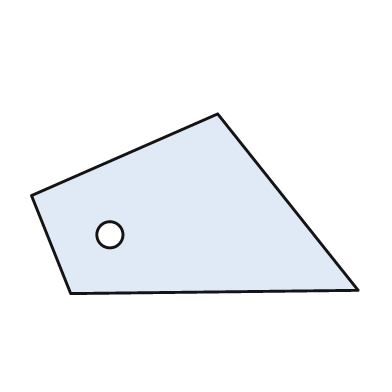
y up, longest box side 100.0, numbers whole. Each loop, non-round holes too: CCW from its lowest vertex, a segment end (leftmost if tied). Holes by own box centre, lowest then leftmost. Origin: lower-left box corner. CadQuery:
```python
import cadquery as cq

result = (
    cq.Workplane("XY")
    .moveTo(12.0, 0.0)
    .lineTo(100.0, 1.0)
    .lineTo(57.0, 55.0)
    .lineTo(0.0, 30.0)
    .close()
    .moveTo(24.0, 18.0)
    .circle(4.0)
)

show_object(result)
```